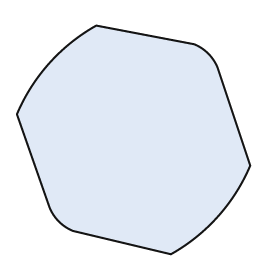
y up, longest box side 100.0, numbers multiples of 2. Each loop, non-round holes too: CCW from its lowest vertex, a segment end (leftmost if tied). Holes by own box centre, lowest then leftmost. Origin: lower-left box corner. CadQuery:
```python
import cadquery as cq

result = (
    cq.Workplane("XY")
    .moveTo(66.0, 0.0)
    .threePointArc((86.0, 16.0), (100.0, 38.0))
    .lineTo(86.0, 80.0)
    .threePointArc((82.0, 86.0), (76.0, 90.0))
    .lineTo(34.0, 98.0)
    .threePointArc((14.0, 82.0), (0.0, 60.0))
    .lineTo(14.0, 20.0)
    .threePointArc((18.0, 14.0), (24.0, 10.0))
    .close()
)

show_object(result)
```